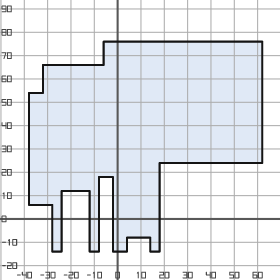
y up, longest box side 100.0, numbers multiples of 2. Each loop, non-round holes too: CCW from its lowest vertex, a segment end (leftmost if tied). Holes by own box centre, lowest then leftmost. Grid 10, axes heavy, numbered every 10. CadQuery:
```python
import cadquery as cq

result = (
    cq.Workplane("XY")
    .moveTo(-28.0, -14.0)
    .lineTo(-24.0, -14.0)
    .lineTo(-24.0, 12.0)
    .lineTo(-12.0, 12.0)
    .lineTo(-12.0, -14.0)
    .lineTo(-8.0, -14.0)
    .lineTo(-8.0, 18.0)
    .lineTo(-2.0, 18.0)
    .lineTo(-2.0, -14.0)
    .lineTo(4.0, -14.0)
    .lineTo(4.0, -8.0)
    .lineTo(14.0, -8.0)
    .lineTo(14.0, -14.0)
    .lineTo(18.0, -14.0)
    .lineTo(18.0, 24.0)
    .lineTo(62.0, 24.0)
    .lineTo(62.0, 76.0)
    .lineTo(-6.0, 76.0)
    .lineTo(-6.0, 66.0)
    .lineTo(-32.0, 66.0)
    .lineTo(-32.0, 54.0)
    .lineTo(-38.0, 54.0)
    .lineTo(-38.0, 6.0)
    .lineTo(-28.0, 6.0)
    .close()
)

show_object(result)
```